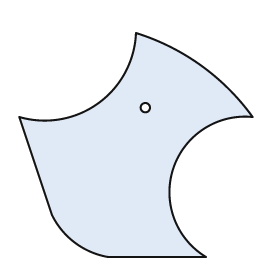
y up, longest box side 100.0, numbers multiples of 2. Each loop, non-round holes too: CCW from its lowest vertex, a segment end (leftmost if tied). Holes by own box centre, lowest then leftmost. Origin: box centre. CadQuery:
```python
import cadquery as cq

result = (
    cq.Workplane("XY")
    .moveTo(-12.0, -48.0)
    .lineTo(30.0, -48.0)
    .threePointArc((16.0, -10.0), (50.0, 12.0))
    .threePointArc((28.0, 34.0), (0.0, 48.0))
    .threePointArc((-16.0, 18.0), (-50.0, 12.0))
    .lineTo(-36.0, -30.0)
    .threePointArc((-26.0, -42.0), (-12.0, -48.0))
    .close()
    .moveTo(4.0, 16.0)
    .circle(2.0)
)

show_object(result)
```